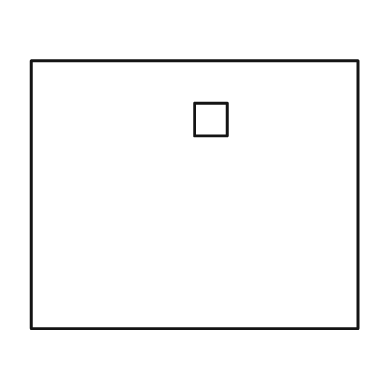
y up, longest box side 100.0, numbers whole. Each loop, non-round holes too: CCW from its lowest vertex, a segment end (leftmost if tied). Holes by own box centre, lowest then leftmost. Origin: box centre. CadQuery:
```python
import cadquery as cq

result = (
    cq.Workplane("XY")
    .moveTo(-50.0, -41.0)
    .lineTo(50.0, -41.0)
    .lineTo(50.0, 41.0)
    .lineTo(-50.0, 41.0)
    .close()
    .moveTo(0.0, 18.0)
    .lineTo(10.0, 18.0)
    .lineTo(10.0, 28.0)
    .lineTo(0.0, 28.0)
    .close()
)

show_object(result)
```